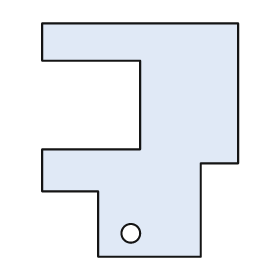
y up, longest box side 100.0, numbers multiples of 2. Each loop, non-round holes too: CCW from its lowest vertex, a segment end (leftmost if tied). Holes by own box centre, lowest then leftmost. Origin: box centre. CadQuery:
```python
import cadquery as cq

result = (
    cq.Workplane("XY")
    .moveTo(-18.0, -50.0)
    .lineTo(26.0, -50.0)
    .lineTo(26.0, -10.0)
    .lineTo(42.0, -10.0)
    .lineTo(42.0, 50.0)
    .lineTo(-42.0, 50.0)
    .lineTo(-42.0, 34.0)
    .lineTo(0.0, 34.0)
    .lineTo(0.0, -4.0)
    .lineTo(-42.0, -4.0)
    .lineTo(-42.0, -22.0)
    .lineTo(-18.0, -22.0)
    .close()
    .moveTo(-4.0, -40.0)
    .circle(4.0)
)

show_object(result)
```